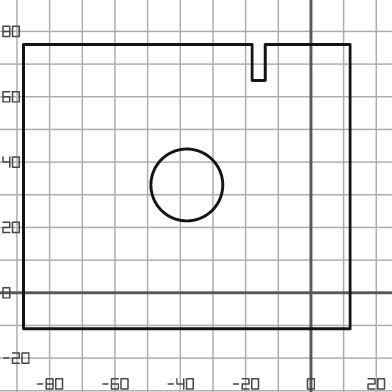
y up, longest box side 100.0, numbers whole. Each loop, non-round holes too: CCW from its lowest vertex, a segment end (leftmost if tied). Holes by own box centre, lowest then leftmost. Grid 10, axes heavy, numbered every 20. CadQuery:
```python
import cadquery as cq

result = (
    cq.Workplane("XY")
    .moveTo(-88.0, -11.0)
    .lineTo(12.0, -11.0)
    .lineTo(12.0, 76.0)
    .lineTo(-14.0, 76.0)
    .lineTo(-14.0, 65.0)
    .lineTo(-18.0, 65.0)
    .lineTo(-18.0, 76.0)
    .lineTo(-88.0, 76.0)
    .close()
    .moveTo(-38.0, 33.0)
    .circle(11.0)
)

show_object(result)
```